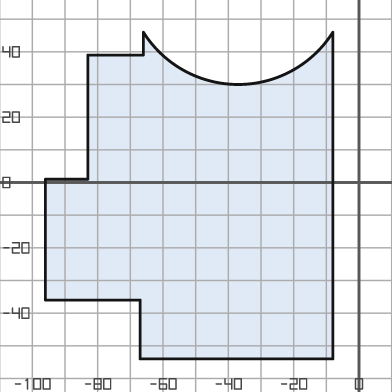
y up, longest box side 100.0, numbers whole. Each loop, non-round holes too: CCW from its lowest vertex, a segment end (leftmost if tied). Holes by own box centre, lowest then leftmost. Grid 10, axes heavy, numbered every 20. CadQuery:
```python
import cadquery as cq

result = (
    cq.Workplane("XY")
    .moveTo(-67.0, -54.0)
    .lineTo(-8.0, -54.0)
    .lineTo(-8.0, 46.0)
    .threePointArc((-37.0, 30.0), (-66.0, 46.0))
    .lineTo(-66.0, 39.0)
    .lineTo(-83.0, 39.0)
    .lineTo(-83.0, 1.0)
    .lineTo(-96.0, 1.0)
    .lineTo(-96.0, -36.0)
    .lineTo(-67.0, -36.0)
    .close()
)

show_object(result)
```